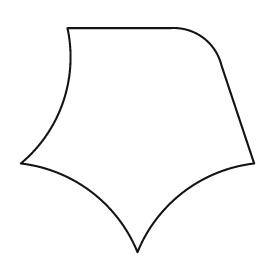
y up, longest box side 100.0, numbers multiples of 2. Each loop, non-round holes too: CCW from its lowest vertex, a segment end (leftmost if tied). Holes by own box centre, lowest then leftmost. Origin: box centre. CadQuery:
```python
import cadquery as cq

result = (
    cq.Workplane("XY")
    .moveTo(0.0, -48.0)
    .threePointArc((20.0, -22.0), (50.0, -10.0))
    .lineTo(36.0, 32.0)
    .threePointArc((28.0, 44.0), (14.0, 48.0))
    .lineTo(-30.0, 48.0)
    .threePointArc((-32.0, 16.0), (-50.0, -10.0))
    .threePointArc((-20.0, -22.0), (0.0, -48.0))
    .close()
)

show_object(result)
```